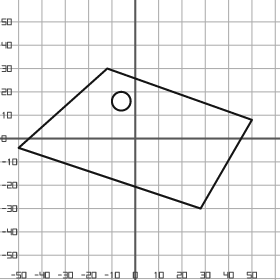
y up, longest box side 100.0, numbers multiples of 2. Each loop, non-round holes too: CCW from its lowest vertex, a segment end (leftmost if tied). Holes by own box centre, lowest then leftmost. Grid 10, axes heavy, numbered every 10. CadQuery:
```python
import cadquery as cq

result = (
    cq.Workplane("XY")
    .moveTo(28.0, -30.0)
    .lineTo(50.0, 8.0)
    .lineTo(-12.0, 30.0)
    .lineTo(-50.0, -4.0)
    .close()
    .moveTo(-6.0, 16.0)
    .circle(4.0)
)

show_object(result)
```